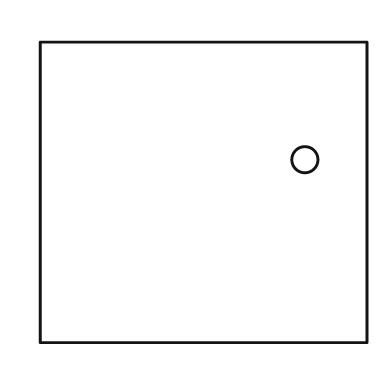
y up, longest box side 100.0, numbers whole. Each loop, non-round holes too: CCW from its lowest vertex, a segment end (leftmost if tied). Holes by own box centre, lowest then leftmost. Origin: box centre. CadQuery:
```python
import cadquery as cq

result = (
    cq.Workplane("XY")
    .moveTo(-50.0, -46.0)
    .lineTo(50.0, -46.0)
    .lineTo(50.0, 46.0)
    .lineTo(-50.0, 46.0)
    .close()
    .moveTo(31.0, 10.0)
    .circle(4.0)
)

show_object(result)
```